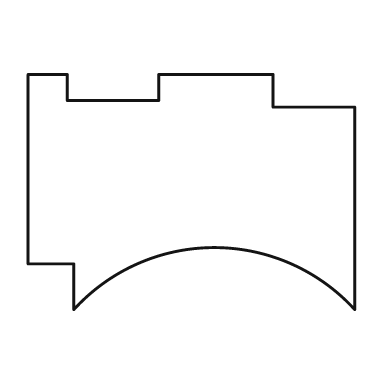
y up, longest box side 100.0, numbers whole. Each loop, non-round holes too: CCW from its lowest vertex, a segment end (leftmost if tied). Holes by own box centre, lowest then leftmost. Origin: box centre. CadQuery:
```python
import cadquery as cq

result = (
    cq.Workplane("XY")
    .moveTo(-36.0, -36.0)
    .threePointArc((7.0, -17.0), (50.0, -36.0))
    .lineTo(50.0, 26.0)
    .lineTo(25.0, 26.0)
    .lineTo(25.0, 36.0)
    .lineTo(-10.0, 36.0)
    .lineTo(-10.0, 28.0)
    .lineTo(-38.0, 28.0)
    .lineTo(-38.0, 36.0)
    .lineTo(-50.0, 36.0)
    .lineTo(-50.0, -22.0)
    .lineTo(-36.0, -22.0)
    .close()
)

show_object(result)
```